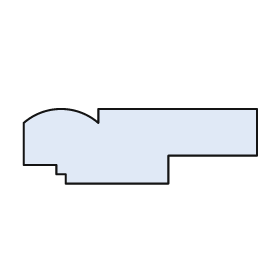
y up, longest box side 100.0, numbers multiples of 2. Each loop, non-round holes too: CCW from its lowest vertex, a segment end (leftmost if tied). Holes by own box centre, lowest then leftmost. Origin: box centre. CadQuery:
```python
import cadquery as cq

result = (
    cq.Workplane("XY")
    .moveTo(-32.0, -16.0)
    .lineTo(12.0, -16.0)
    .lineTo(12.0, -4.0)
    .lineTo(50.0, -4.0)
    .lineTo(50.0, 16.0)
    .lineTo(-18.0, 16.0)
    .lineTo(-18.0, 10.0)
    .threePointArc((-34.0, 16.0), (-50.0, 10.0))
    .lineTo(-50.0, -8.0)
    .lineTo(-36.0, -8.0)
    .lineTo(-36.0, -12.0)
    .lineTo(-32.0, -12.0)
    .close()
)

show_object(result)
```